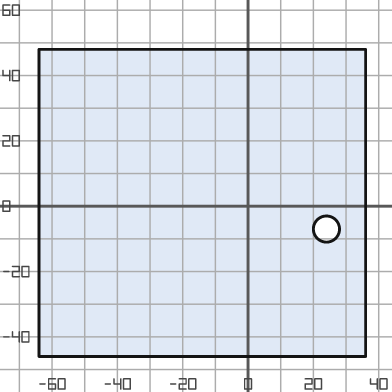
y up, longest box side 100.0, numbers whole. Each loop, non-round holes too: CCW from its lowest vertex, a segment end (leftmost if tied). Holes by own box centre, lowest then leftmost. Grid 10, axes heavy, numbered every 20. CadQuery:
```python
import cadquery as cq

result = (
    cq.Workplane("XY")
    .moveTo(-64.0, -46.0)
    .lineTo(36.0, -46.0)
    .lineTo(36.0, 48.0)
    .lineTo(-64.0, 48.0)
    .close()
    .moveTo(24.0, -7.0)
    .circle(4.0)
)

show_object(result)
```